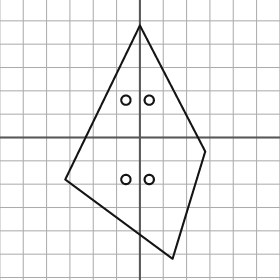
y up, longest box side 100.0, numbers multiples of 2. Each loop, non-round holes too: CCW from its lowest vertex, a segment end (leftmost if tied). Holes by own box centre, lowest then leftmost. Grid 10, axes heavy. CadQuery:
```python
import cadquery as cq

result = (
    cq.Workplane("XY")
    .moveTo(14.0, -52.0)
    .lineTo(28.0, -6.0)
    .lineTo(0.0, 48.0)
    .lineTo(-32.0, -18.0)
    .close()
    .moveTo(-6.0, -18.0)
    .circle(2.0)
    .moveTo(4.0, -18.0)
    .circle(2.0)
    .moveTo(-6.0, 16.0)
    .circle(2.0)
    .moveTo(4.0, 16.0)
    .circle(2.0)
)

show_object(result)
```